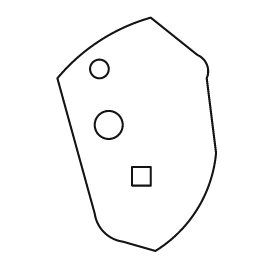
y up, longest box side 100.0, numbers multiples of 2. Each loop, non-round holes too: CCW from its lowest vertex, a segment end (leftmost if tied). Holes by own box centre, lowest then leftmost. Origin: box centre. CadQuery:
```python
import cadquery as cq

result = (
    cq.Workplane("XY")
    .moveTo(8.0, -50.0)
    .threePointArc((26.0, -32.0), (34.0, -8.0))
    .lineTo(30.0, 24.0)
    .threePointArc((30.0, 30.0), (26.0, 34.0))
    .lineTo(6.0, 50.0)
    .threePointArc((-16.0, 40.0), (-34.0, 24.0))
    .lineTo(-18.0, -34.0)
    .threePointArc((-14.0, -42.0), (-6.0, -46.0))
    .close()
    .moveTo(-2.0, -22.0)
    .lineTo(6.0, -22.0)
    .lineTo(6.0, -14.0)
    .lineTo(-2.0, -14.0)
    .close()
    .moveTo(-12.0, 4.0)
    .circle(6.0)
    .moveTo(-16.0, 28.0)
    .circle(4.0)
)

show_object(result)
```